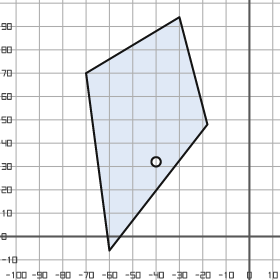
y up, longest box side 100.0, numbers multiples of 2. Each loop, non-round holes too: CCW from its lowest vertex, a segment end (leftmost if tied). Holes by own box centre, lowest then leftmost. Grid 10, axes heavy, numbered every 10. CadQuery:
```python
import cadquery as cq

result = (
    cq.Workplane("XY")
    .moveTo(-60.0, -6.0)
    .lineTo(-18.0, 48.0)
    .lineTo(-30.0, 94.0)
    .lineTo(-70.0, 70.0)
    .close()
    .moveTo(-40.0, 32.0)
    .circle(2.0)
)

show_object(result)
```